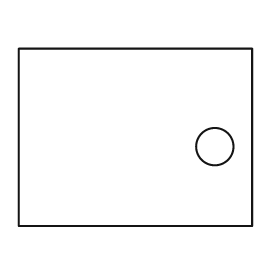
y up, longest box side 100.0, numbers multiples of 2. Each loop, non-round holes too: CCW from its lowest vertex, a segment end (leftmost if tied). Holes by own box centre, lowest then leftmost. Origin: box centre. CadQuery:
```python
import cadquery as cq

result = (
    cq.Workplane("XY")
    .moveTo(-50.0, -38.0)
    .lineTo(50.0, -38.0)
    .lineTo(50.0, 38.0)
    .lineTo(-50.0, 38.0)
    .close()
    .moveTo(34.0, -4.0)
    .circle(8.0)
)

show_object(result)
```